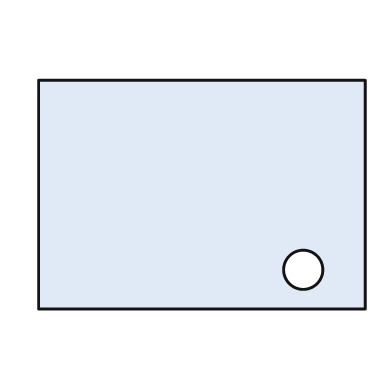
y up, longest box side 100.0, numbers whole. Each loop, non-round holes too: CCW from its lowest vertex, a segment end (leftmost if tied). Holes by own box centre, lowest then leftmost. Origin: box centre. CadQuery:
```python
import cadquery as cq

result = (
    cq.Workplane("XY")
    .moveTo(-50.0, -35.0)
    .lineTo(50.0, -35.0)
    .lineTo(50.0, 35.0)
    .lineTo(-50.0, 35.0)
    .close()
    .moveTo(31.0, -23.0)
    .circle(6.0)
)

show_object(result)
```